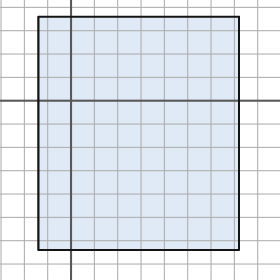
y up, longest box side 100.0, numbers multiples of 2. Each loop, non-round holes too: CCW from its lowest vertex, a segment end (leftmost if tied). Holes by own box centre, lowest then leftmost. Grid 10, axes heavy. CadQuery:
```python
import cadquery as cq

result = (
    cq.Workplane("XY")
    .moveTo(-14.0, -64.0)
    .lineTo(72.0, -64.0)
    .lineTo(72.0, 36.0)
    .lineTo(-14.0, 36.0)
    .close()
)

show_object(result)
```